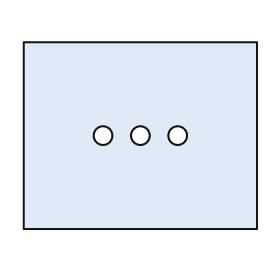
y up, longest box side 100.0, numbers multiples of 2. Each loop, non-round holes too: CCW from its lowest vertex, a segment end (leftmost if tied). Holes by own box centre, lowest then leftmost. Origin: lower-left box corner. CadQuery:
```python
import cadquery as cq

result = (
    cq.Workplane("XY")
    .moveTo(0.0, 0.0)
    .lineTo(100.0, 0.0)
    .lineTo(100.0, 80.0)
    .lineTo(0.0, 80.0)
    .close()
    .moveTo(34.0, 40.0)
    .circle(4.0)
    .moveTo(50.0, 40.0)
    .circle(4.0)
    .moveTo(66.0, 40.0)
    .circle(4.0)
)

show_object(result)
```